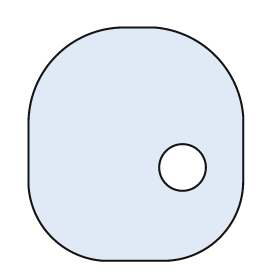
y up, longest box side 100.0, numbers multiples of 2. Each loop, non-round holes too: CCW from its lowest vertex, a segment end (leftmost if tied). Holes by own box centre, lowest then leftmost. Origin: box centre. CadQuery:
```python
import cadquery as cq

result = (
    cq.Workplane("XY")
    .moveTo(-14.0, -50.0)
    .lineTo(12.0, -50.0)
    .threePointArc((36.0, -40.0), (46.0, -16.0))
    .lineTo(46.0, 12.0)
    .threePointArc((34.0, 38.0), (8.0, 50.0))
    .lineTo(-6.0, 50.0)
    .threePointArc((-34.0, 38.0), (-46.0, 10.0))
    .lineTo(-46.0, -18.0)
    .threePointArc((-36.0, -40.0), (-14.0, -50.0))
    .close()
    .moveTo(20.0, -10.0)
    .circle(10.0)
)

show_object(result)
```